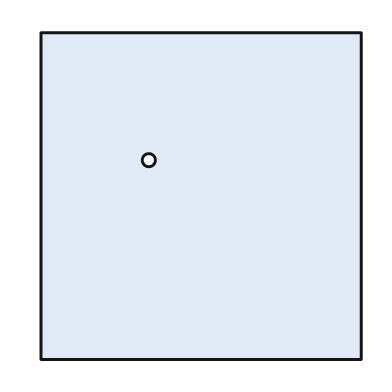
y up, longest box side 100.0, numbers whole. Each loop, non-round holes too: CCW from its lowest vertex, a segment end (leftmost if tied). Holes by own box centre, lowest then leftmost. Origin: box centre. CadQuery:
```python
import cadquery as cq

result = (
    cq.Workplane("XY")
    .moveTo(-49.0, -50.0)
    .lineTo(49.0, -50.0)
    .lineTo(49.0, 50.0)
    .lineTo(-49.0, 50.0)
    .close()
    .moveTo(-16.0, 11.0)
    .circle(2.0)
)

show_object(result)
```